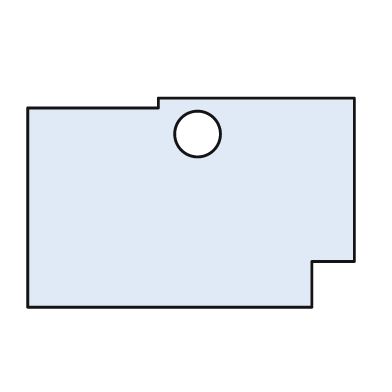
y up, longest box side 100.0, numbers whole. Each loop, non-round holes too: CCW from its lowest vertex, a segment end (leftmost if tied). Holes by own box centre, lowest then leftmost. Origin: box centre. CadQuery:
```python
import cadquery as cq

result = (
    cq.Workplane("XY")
    .moveTo(-50.0, -32.0)
    .lineTo(37.0, -32.0)
    .lineTo(37.0, -18.0)
    .lineTo(50.0, -18.0)
    .lineTo(50.0, 32.0)
    .lineTo(-10.0, 32.0)
    .lineTo(-10.0, 29.0)
    .lineTo(-50.0, 29.0)
    .close()
    .moveTo(2.0, 21.0)
    .circle(7.0)
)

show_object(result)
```